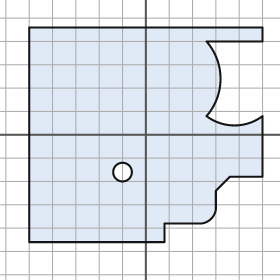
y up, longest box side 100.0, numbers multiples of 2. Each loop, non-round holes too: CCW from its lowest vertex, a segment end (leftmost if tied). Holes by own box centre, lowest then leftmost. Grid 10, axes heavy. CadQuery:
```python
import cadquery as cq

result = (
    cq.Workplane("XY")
    .moveTo(-50.0, -46.0)
    .lineTo(8.0, -46.0)
    .lineTo(8.0, -38.0)
    .lineTo(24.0, -38.0)
    .threePointArc((28.0, -36.0), (30.0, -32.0))
    .lineTo(30.0, -24.0)
    .lineTo(36.0, -18.0)
    .lineTo(50.0, -18.0)
    .lineTo(50.0, 8.0)
    .threePointArc((38.0, 4.0), (26.0, 8.0))
    .threePointArc((32.0, 24.0), (26.0, 40.0))
    .lineTo(50.0, 40.0)
    .lineTo(50.0, 46.0)
    .lineTo(-50.0, 46.0)
    .close()
    .moveTo(-10.0, -16.0)
    .circle(4.0)
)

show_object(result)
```